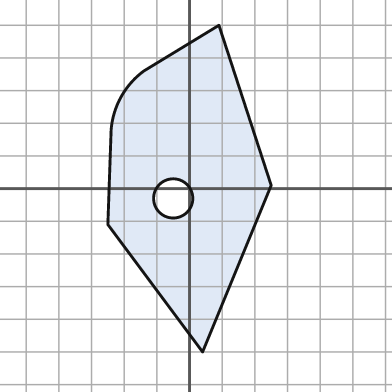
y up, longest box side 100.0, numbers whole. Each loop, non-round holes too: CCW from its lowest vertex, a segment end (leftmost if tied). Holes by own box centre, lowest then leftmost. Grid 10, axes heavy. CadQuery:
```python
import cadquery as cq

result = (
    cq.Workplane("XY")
    .moveTo(4.0, -50.0)
    .lineTo(25.0, 1.0)
    .lineTo(9.0, 50.0)
    .lineTo(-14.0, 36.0)
    .threePointArc((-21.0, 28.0), (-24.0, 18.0))
    .lineTo(-25.0, -11.0)
    .close()
    .moveTo(-5.0, -3.0)
    .circle(6.0)
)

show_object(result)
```